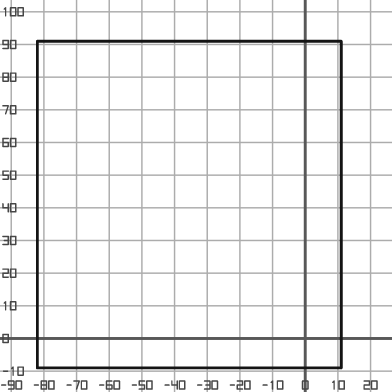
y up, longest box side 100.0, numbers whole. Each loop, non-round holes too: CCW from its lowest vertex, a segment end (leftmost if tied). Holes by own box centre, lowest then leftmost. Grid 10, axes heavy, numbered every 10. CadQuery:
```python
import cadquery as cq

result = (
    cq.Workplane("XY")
    .moveTo(-82.0, -9.0)
    .lineTo(11.0, -9.0)
    .lineTo(11.0, 91.0)
    .lineTo(-82.0, 91.0)
    .close()
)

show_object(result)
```